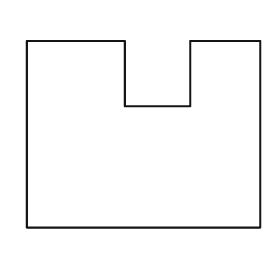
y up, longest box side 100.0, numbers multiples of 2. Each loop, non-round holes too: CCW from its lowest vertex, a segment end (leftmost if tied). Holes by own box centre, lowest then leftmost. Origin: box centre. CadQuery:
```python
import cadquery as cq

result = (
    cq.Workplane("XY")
    .moveTo(-50.0, -40.0)
    .lineTo(50.0, -40.0)
    .lineTo(50.0, 40.0)
    .lineTo(20.0, 40.0)
    .lineTo(20.0, 12.0)
    .lineTo(-8.0, 12.0)
    .lineTo(-8.0, 40.0)
    .lineTo(-50.0, 40.0)
    .close()
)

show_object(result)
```